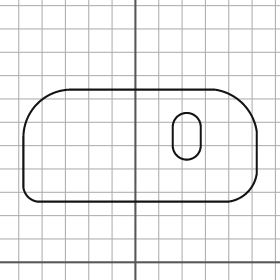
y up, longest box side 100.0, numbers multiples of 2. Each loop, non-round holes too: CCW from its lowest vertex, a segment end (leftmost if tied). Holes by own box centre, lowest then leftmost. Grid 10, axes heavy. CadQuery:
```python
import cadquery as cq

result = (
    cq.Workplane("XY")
    .moveTo(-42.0, 26.0)
    .lineTo(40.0, 26.0)
    .threePointArc((48.0, 30.0), (52.0, 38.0))
    .lineTo(52.0, 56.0)
    .threePointArc((46.0, 68.0), (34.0, 74.0))
    .lineTo(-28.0, 74.0)
    .threePointArc((-42.0, 68.0), (-48.0, 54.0))
    .lineTo(-48.0, 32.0)
    .threePointArc((-46.0, 28.0), (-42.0, 26.0))
    .close()
    .moveTo(16.0, 50.0)
    .threePointArc((22.0, 44.0), (28.0, 50.0))
    .lineTo(28.0, 58.0)
    .threePointArc((22.0, 64.0), (16.0, 58.0))
    .close()
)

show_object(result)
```